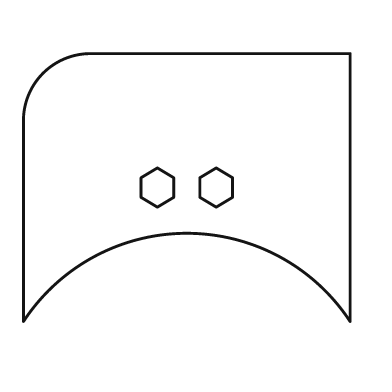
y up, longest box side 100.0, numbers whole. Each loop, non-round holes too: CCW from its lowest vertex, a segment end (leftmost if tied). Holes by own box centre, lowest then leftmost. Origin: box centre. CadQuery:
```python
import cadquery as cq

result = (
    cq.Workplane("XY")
    .moveTo(-50.0, -41.0)
    .threePointArc((0.0, -14.0), (50.0, -41.0))
    .lineTo(50.0, 41.0)
    .lineTo(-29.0, 41.0)
    .threePointArc((-44.0, 35.0), (-50.0, 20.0))
    .close()
    .moveTo(-9.0, -6.0)
    .lineTo(-4.0, -3.0)
    .lineTo(-4.0, 3.0)
    .lineTo(-9.0, 6.0)
    .lineTo(-14.0, 3.0)
    .lineTo(-14.0, -3.0)
    .close()
    .moveTo(9.0, -6.0)
    .lineTo(14.0, -3.0)
    .lineTo(14.0, 3.0)
    .lineTo(9.0, 6.0)
    .lineTo(4.0, 3.0)
    .lineTo(4.0, -3.0)
    .close()
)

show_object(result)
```